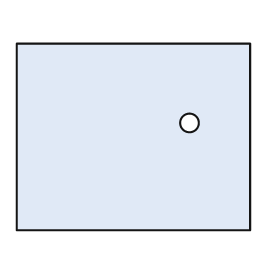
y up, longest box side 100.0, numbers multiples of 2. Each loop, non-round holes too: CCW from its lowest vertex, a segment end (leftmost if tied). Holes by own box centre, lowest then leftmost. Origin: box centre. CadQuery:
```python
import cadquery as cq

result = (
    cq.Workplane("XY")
    .moveTo(-50.0, -40.0)
    .lineTo(50.0, -40.0)
    .lineTo(50.0, 40.0)
    .lineTo(-50.0, 40.0)
    .close()
    .moveTo(24.0, 6.0)
    .circle(4.0)
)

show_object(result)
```